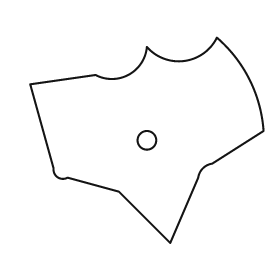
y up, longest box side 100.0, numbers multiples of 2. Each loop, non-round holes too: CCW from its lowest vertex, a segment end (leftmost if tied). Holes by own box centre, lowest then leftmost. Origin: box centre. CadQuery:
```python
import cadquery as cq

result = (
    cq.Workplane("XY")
    .moveTo(10.0, -44.0)
    .lineTo(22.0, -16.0)
    .threePointArc((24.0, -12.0), (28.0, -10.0))
    .lineTo(50.0, 4.0)
    .threePointArc((44.0, 26.0), (30.0, 44.0))
    .threePointArc((16.0, 34.0), (0.0, 40.0))
    .threePointArc((-8.0, 28.0), (-22.0, 28.0))
    .lineTo(-50.0, 24.0)
    .lineTo(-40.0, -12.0)
    .threePointArc((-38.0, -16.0), (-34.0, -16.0))
    .lineTo(-12.0, -22.0)
    .close()
    .moveTo(0.0, 0.0)
    .circle(4.0)
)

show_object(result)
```